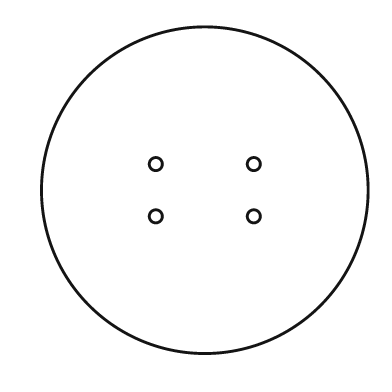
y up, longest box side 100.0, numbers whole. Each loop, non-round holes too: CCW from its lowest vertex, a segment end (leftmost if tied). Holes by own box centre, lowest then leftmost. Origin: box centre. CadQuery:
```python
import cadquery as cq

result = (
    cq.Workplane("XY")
    .moveTo(0.0, 0.0)
    .circle(50.0)
    .moveTo(-15.0, -8.0)
    .circle(2.0)
    .moveTo(15.0, -8.0)
    .circle(2.0)
    .moveTo(-15.0, 8.0)
    .circle(2.0)
    .moveTo(15.0, 8.0)
    .circle(2.0)
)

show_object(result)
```